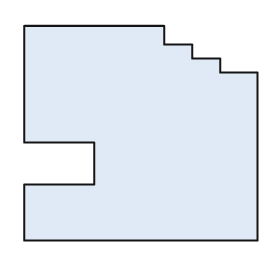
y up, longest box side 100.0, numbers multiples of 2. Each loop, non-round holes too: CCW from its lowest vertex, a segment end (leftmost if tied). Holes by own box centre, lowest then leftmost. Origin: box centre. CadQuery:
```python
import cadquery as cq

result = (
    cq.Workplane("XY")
    .moveTo(-50.0, -46.0)
    .lineTo(50.0, -46.0)
    .lineTo(50.0, 26.0)
    .lineTo(34.0, 26.0)
    .lineTo(34.0, 32.0)
    .lineTo(22.0, 32.0)
    .lineTo(22.0, 38.0)
    .lineTo(10.0, 38.0)
    .lineTo(10.0, 46.0)
    .lineTo(-50.0, 46.0)
    .lineTo(-50.0, -4.0)
    .lineTo(-20.0, -4.0)
    .lineTo(-20.0, -22.0)
    .lineTo(-50.0, -22.0)
    .close()
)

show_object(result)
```